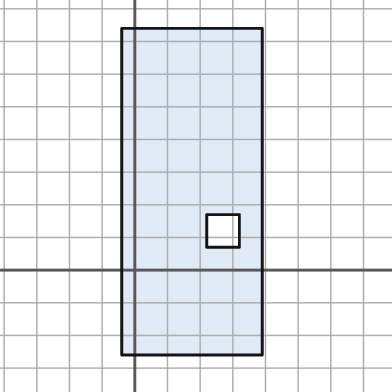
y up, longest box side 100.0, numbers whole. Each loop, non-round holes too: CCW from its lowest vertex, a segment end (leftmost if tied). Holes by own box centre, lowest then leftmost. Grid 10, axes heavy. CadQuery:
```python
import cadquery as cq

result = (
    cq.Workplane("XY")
    .moveTo(-4.0, -26.0)
    .lineTo(39.0, -26.0)
    .lineTo(39.0, 74.0)
    .lineTo(-4.0, 74.0)
    .close()
    .moveTo(22.0, 7.0)
    .lineTo(32.0, 7.0)
    .lineTo(32.0, 17.0)
    .lineTo(22.0, 17.0)
    .close()
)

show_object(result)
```